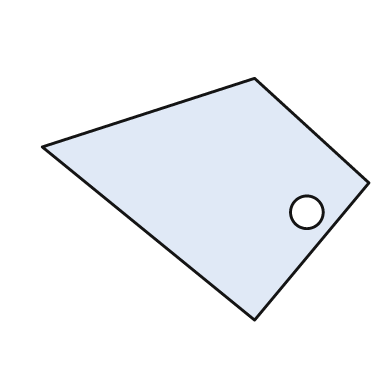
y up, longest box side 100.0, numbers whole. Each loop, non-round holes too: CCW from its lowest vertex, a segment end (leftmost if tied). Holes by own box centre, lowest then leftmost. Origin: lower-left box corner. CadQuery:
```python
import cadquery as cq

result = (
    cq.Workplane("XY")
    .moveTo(65.0, 0.0)
    .lineTo(100.0, 42.0)
    .lineTo(65.0, 74.0)
    .lineTo(0.0, 53.0)
    .close()
    .moveTo(81.0, 33.0)
    .circle(5.0)
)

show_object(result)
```